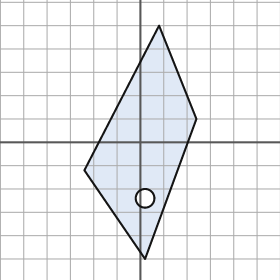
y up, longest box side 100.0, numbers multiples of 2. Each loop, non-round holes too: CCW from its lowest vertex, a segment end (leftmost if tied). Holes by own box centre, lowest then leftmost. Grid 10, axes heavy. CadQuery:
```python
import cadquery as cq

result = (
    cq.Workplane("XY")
    .moveTo(2.0, -50.0)
    .lineTo(24.0, 10.0)
    .lineTo(8.0, 50.0)
    .lineTo(-24.0, -12.0)
    .close()
    .moveTo(2.0, -24.0)
    .circle(4.0)
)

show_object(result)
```